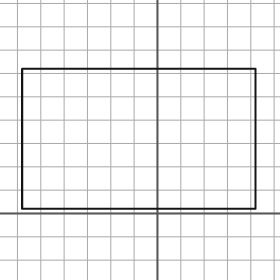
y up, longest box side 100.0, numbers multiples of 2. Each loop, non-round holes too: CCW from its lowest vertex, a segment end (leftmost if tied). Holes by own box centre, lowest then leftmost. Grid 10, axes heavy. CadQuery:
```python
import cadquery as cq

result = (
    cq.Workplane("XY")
    .moveTo(-58.0, 2.0)
    .lineTo(42.0, 2.0)
    .lineTo(42.0, 62.0)
    .lineTo(-58.0, 62.0)
    .close()
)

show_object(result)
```